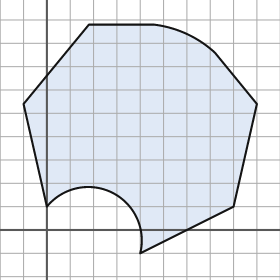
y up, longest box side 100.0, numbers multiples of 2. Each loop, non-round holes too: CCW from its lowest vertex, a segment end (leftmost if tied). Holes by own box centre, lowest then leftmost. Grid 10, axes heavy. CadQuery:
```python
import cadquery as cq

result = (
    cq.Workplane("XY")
    .moveTo(40.0, -10.0)
    .lineTo(80.0, 10.0)
    .lineTo(90.0, 54.0)
    .lineTo(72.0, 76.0)
    .threePointArc((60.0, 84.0), (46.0, 88.0))
    .lineTo(18.0, 88.0)
    .lineTo(-10.0, 54.0)
    .lineTo(0.0, 10.0)
    .threePointArc((28.0, 16.0), (40.0, -10.0))
    .close()
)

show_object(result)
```